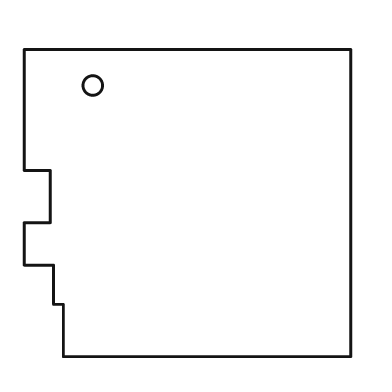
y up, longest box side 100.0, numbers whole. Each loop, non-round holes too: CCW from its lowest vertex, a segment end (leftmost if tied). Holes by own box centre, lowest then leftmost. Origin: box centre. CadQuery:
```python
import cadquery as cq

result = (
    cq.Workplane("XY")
    .moveTo(-38.0, -47.0)
    .lineTo(50.0, -47.0)
    .lineTo(50.0, 47.0)
    .lineTo(-50.0, 47.0)
    .lineTo(-50.0, 10.0)
    .lineTo(-42.0, 10.0)
    .lineTo(-42.0, -6.0)
    .lineTo(-50.0, -6.0)
    .lineTo(-50.0, -19.0)
    .lineTo(-41.0, -19.0)
    .lineTo(-41.0, -31.0)
    .lineTo(-38.0, -31.0)
    .close()
    .moveTo(-29.0, 36.0)
    .circle(3.0)
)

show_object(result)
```